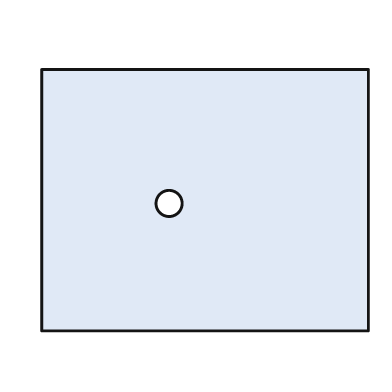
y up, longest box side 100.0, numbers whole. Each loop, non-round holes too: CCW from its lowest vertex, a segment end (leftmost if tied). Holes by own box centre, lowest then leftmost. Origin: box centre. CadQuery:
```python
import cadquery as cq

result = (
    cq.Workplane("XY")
    .moveTo(-50.0, -40.0)
    .lineTo(50.0, -40.0)
    .lineTo(50.0, 40.0)
    .lineTo(-50.0, 40.0)
    .close()
    .moveTo(-11.0, -1.0)
    .circle(4.0)
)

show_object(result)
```